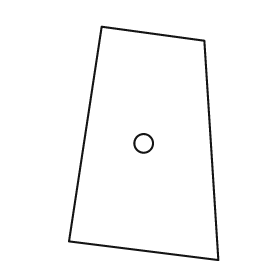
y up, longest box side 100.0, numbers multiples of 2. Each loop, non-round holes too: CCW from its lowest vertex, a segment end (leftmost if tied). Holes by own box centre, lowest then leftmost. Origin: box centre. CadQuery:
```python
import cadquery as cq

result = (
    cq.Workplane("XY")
    .moveTo(32.0, -50.0)
    .lineTo(26.0, 44.0)
    .lineTo(-18.0, 50.0)
    .lineTo(-32.0, -42.0)
    .close()
    .moveTo(0.0, 0.0)
    .circle(4.0)
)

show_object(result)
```